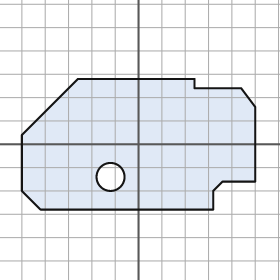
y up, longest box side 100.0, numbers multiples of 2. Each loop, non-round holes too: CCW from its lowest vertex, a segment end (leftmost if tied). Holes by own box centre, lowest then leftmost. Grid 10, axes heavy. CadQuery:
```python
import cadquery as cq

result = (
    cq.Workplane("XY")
    .moveTo(-42.0, -28.0)
    .lineTo(32.0, -28.0)
    .lineTo(32.0, -20.0)
    .lineTo(36.0, -16.0)
    .lineTo(50.0, -16.0)
    .lineTo(50.0, 16.0)
    .lineTo(44.0, 24.0)
    .lineTo(24.0, 24.0)
    .lineTo(24.0, 28.0)
    .lineTo(-26.0, 28.0)
    .lineTo(-50.0, 4.0)
    .lineTo(-50.0, -20.0)
    .close()
    .moveTo(-12.0, -14.0)
    .circle(6.0)
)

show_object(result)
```